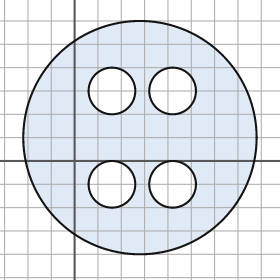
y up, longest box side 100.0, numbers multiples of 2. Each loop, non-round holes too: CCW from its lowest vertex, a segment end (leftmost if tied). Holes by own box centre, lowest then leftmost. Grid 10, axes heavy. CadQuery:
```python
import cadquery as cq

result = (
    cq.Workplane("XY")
    .moveTo(28.0, 10.0)
    .circle(50.0)
    .moveTo(16.0, -10.0)
    .circle(10.0)
    .moveTo(42.0, -10.0)
    .circle(10.0)
    .moveTo(16.0, 30.0)
    .circle(10.0)
    .moveTo(42.0, 30.0)
    .circle(10.0)
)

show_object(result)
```